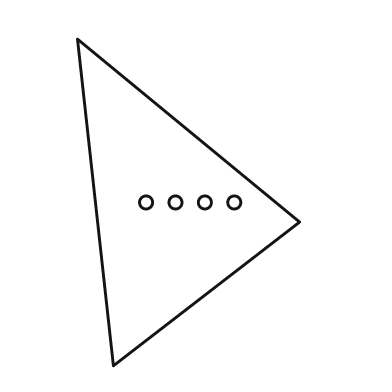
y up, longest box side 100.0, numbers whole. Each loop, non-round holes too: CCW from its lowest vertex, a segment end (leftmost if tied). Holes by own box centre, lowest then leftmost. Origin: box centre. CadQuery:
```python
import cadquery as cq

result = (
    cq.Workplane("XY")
    .moveTo(-23.0, -50.0)
    .lineTo(34.0, -6.0)
    .lineTo(-34.0, 50.0)
    .close()
    .moveTo(-13.0, 0.0)
    .circle(2.0)
    .moveTo(-4.0, 0.0)
    .circle(2.0)
    .moveTo(5.0, 0.0)
    .circle(2.0)
    .moveTo(14.0, 0.0)
    .circle(2.0)
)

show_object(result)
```